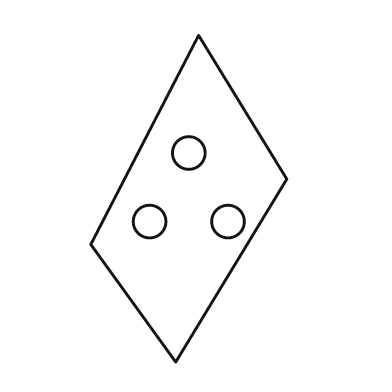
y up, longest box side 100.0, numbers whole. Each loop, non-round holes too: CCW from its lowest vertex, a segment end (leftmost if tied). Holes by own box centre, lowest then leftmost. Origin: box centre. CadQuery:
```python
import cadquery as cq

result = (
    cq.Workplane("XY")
    .moveTo(-4.0, -50.0)
    .lineTo(30.0, 6.0)
    .lineTo(3.0, 50.0)
    .lineTo(-30.0, -14.0)
    .close()
    .moveTo(-12.0, -7.0)
    .circle(5.0)
    .moveTo(12.0, -7.0)
    .circle(5.0)
    .moveTo(0.0, 14.0)
    .circle(5.0)
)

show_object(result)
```